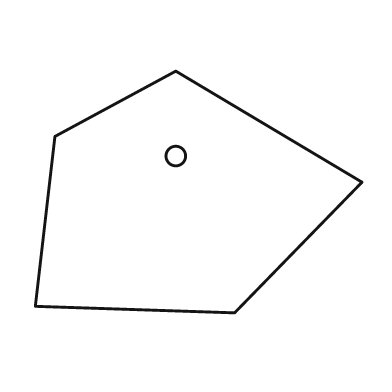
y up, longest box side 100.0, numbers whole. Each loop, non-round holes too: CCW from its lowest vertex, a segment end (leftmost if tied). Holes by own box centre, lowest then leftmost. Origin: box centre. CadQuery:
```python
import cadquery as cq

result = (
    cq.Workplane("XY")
    .moveTo(11.0, -37.0)
    .lineTo(50.0, 3.0)
    .lineTo(-7.0, 37.0)
    .lineTo(-44.0, 17.0)
    .lineTo(-50.0, -35.0)
    .close()
    .moveTo(-7.0, 11.0)
    .circle(3.0)
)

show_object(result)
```